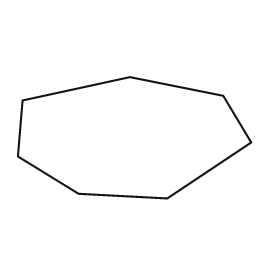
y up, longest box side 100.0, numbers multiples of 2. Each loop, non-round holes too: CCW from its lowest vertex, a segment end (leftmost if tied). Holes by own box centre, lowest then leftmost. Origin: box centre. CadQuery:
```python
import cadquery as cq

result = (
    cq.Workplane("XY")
    .moveTo(14.0, -26.0)
    .lineTo(50.0, -2.0)
    .lineTo(38.0, 18.0)
    .lineTo(-2.0, 26.0)
    .lineTo(-48.0, 16.0)
    .lineTo(-50.0, -8.0)
    .lineTo(-24.0, -24.0)
    .close()
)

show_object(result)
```